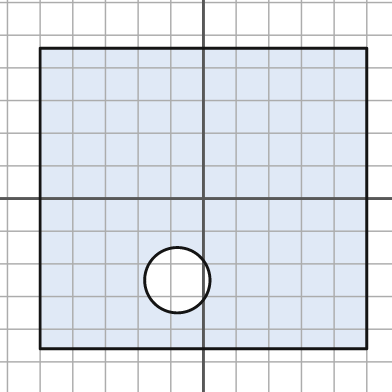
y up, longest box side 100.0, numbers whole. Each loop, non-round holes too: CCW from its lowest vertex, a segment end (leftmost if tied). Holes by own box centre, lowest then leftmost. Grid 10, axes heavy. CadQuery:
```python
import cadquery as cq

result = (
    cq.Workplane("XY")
    .moveTo(-50.0, -46.0)
    .lineTo(50.0, -46.0)
    .lineTo(50.0, 46.0)
    .lineTo(-50.0, 46.0)
    .close()
    .moveTo(-8.0, -25.0)
    .circle(10.0)
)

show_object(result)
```